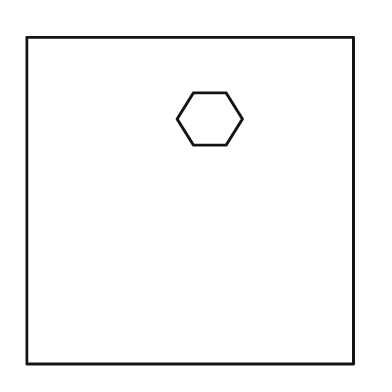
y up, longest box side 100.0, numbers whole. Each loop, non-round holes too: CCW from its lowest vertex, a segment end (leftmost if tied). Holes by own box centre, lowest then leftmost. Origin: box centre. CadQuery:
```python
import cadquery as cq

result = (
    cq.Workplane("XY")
    .moveTo(-50.0, -50.0)
    .lineTo(50.0, -50.0)
    .lineTo(50.0, 50.0)
    .lineTo(-50.0, 50.0)
    .close()
    .moveTo(1.0, 17.0)
    .lineTo(11.0, 17.0)
    .lineTo(16.0, 25.0)
    .lineTo(11.0, 33.0)
    .lineTo(1.0, 33.0)
    .lineTo(-4.0, 25.0)
    .close()
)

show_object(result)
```